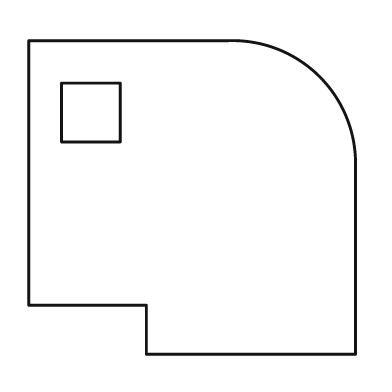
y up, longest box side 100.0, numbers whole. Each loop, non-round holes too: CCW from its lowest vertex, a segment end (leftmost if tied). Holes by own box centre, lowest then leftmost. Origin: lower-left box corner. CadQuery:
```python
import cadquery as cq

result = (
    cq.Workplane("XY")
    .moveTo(36.0, 0.0)
    .lineTo(100.0, 0.0)
    .lineTo(100.0, 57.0)
    .threePointArc((89.0, 85.0), (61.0, 96.0))
    .lineTo(0.0, 96.0)
    .lineTo(0.0, 15.0)
    .lineTo(36.0, 15.0)
    .close()
    .moveTo(10.0, 65.0)
    .lineTo(28.0, 65.0)
    .lineTo(28.0, 83.0)
    .lineTo(10.0, 83.0)
    .close()
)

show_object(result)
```